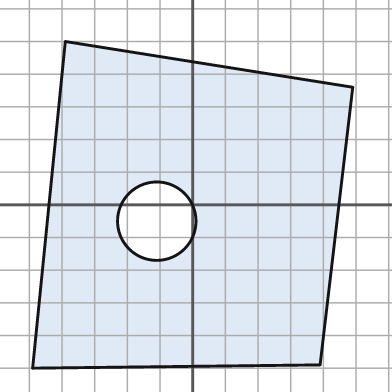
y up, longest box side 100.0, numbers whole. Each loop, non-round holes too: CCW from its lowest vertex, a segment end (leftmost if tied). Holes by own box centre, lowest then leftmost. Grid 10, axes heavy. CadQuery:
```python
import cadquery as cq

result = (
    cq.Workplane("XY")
    .moveTo(-49.0, -50.0)
    .lineTo(39.0, -49.0)
    .lineTo(49.0, 36.0)
    .lineTo(-39.0, 50.0)
    .close()
    .moveTo(-11.0, -5.0)
    .circle(12.0)
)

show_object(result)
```